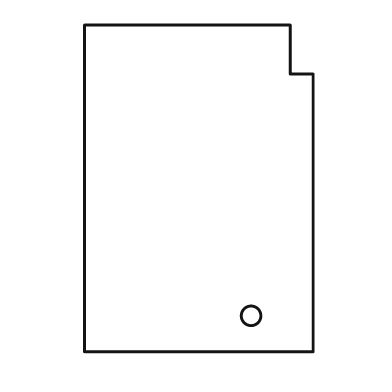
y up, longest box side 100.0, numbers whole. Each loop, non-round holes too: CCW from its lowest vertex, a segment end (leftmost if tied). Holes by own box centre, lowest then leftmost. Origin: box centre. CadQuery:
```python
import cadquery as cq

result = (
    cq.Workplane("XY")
    .moveTo(-35.0, -50.0)
    .lineTo(35.0, -50.0)
    .lineTo(35.0, 35.0)
    .lineTo(28.0, 35.0)
    .lineTo(28.0, 50.0)
    .lineTo(-35.0, 50.0)
    .close()
    .moveTo(16.0, -39.0)
    .circle(3.0)
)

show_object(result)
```